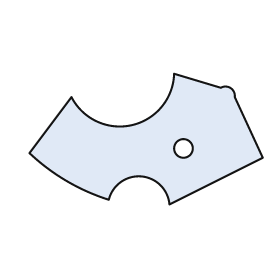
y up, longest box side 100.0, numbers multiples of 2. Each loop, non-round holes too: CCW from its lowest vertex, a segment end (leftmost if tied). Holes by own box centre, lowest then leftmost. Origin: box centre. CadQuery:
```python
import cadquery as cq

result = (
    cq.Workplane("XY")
    .moveTo(10.0, -28.0)
    .lineTo(50.0, -8.0)
    .lineTo(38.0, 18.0)
    .threePointArc((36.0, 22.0), (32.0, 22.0))
    .lineTo(12.0, 28.0)
    .threePointArc((-6.0, 6.0), (-32.0, 18.0))
    .lineTo(-50.0, -6.0)
    .threePointArc((-34.0, -18.0), (-16.0, -26.0))
    .threePointArc((-2.0, -16.0), (10.0, -28.0))
    .close()
    .moveTo(16.0, -4.0)
    .circle(4.0)
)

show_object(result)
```